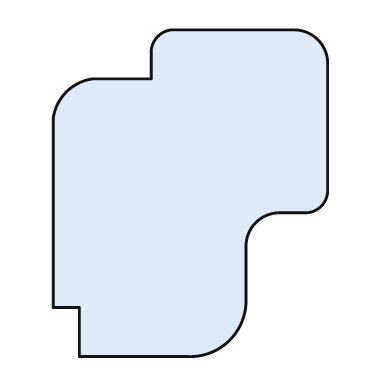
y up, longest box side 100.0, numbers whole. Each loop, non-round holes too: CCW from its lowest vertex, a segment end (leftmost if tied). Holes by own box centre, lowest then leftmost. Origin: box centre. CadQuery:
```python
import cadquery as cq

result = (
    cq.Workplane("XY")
    .moveTo(-34.0, -50.0)
    .lineTo(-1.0, -50.0)
    .threePointArc((12.0, -45.0), (17.0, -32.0))
    .lineTo(17.0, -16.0)
    .threePointArc((20.0, -9.0), (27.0, -6.0))
    .lineTo(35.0, -6.0)
    .threePointArc((40.0, -4.0), (42.0, 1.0))
    .lineTo(42.0, 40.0)
    .threePointArc((39.0, 47.0), (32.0, 50.0))
    .lineTo(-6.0, 50.0)
    .threePointArc((-10.0, 48.0), (-12.0, 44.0))
    .lineTo(-12.0, 35.0)
    .lineTo(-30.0, 35.0)
    .threePointArc((-38.0, 31.0), (-42.0, 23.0))
    .lineTo(-42.0, -35.0)
    .lineTo(-34.0, -35.0)
    .close()
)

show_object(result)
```